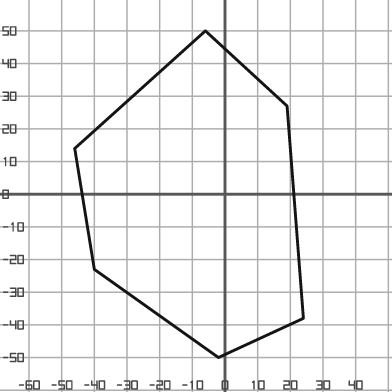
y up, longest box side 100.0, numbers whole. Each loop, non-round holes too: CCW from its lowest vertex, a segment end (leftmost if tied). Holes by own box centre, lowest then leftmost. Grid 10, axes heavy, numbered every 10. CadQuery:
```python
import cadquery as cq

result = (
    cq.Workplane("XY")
    .moveTo(-2.0, -50.0)
    .lineTo(24.0, -38.0)
    .lineTo(19.0, 27.0)
    .lineTo(-6.0, 50.0)
    .lineTo(-46.0, 14.0)
    .lineTo(-40.0, -23.0)
    .close()
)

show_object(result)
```